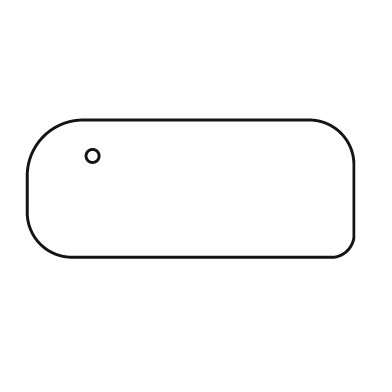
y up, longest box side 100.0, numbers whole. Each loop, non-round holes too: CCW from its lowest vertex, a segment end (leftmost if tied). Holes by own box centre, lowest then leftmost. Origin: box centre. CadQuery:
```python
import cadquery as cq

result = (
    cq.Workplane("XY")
    .moveTo(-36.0, -21.0)
    .lineTo(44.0, -21.0)
    .threePointArc((48.0, -19.0), (50.0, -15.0))
    .lineTo(50.0, 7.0)
    .threePointArc((46.0, 17.0), (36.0, 21.0))
    .lineTo(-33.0, 21.0)
    .threePointArc((-45.0, 16.0), (-50.0, 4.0))
    .lineTo(-50.0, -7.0)
    .threePointArc((-46.0, -17.0), (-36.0, -21.0))
    .close()
    .moveTo(-30.0, 10.0)
    .circle(2.0)
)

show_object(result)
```